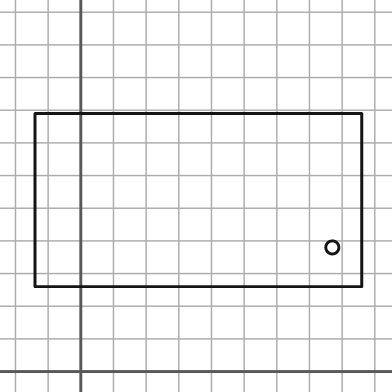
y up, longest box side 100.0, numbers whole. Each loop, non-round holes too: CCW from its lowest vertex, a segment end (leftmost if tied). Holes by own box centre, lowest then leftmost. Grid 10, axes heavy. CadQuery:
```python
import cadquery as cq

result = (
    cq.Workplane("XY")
    .moveTo(-14.0, 26.0)
    .lineTo(86.0, 26.0)
    .lineTo(86.0, 79.0)
    .lineTo(-14.0, 79.0)
    .close()
    .moveTo(77.0, 38.0)
    .circle(2.0)
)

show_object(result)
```